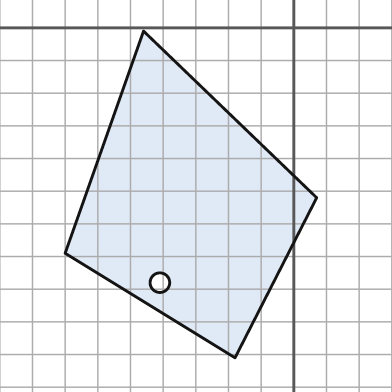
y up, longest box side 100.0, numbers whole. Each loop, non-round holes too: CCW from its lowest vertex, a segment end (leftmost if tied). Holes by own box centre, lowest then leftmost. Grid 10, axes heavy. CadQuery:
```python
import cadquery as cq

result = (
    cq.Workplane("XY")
    .moveTo(-18.0, -101.0)
    .lineTo(7.0, -52.0)
    .lineTo(-46.0, -1.0)
    .lineTo(-70.0, -69.0)
    .close()
    .moveTo(-41.0, -78.0)
    .circle(3.0)
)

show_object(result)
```